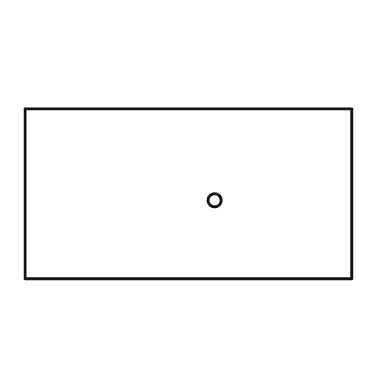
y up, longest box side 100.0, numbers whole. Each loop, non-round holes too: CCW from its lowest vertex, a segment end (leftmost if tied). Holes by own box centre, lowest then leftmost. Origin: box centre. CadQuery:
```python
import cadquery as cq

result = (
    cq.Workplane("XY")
    .moveTo(-50.0, -26.0)
    .lineTo(50.0, -26.0)
    .lineTo(50.0, 26.0)
    .lineTo(-50.0, 26.0)
    .close()
    .moveTo(8.0, -2.0)
    .circle(2.0)
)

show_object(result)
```